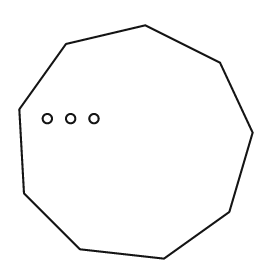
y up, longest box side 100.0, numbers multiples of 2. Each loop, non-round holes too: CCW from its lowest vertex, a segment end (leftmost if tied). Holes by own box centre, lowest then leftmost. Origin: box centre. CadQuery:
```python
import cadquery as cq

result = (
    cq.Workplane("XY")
    .moveTo(12.0, -50.0)
    .lineTo(40.0, -30.0)
    .lineTo(50.0, 4.0)
    .lineTo(36.0, 34.0)
    .lineTo(4.0, 50.0)
    .lineTo(-30.0, 42.0)
    .lineTo(-50.0, 14.0)
    .lineTo(-48.0, -22.0)
    .lineTo(-24.0, -46.0)
    .close()
    .moveTo(-38.0, 10.0)
    .circle(2.0)
    .moveTo(-28.0, 10.0)
    .circle(2.0)
    .moveTo(-18.0, 10.0)
    .circle(2.0)
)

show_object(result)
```